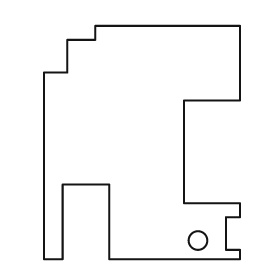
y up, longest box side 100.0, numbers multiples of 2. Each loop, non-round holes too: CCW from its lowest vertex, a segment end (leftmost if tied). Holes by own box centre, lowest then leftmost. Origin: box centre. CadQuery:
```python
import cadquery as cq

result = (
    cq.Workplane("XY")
    .moveTo(-42.0, -50.0)
    .lineTo(-34.0, -50.0)
    .lineTo(-34.0, -18.0)
    .lineTo(-14.0, -18.0)
    .lineTo(-14.0, -50.0)
    .lineTo(42.0, -50.0)
    .lineTo(42.0, -46.0)
    .lineTo(36.0, -46.0)
    .lineTo(36.0, -32.0)
    .lineTo(42.0, -32.0)
    .lineTo(42.0, -26.0)
    .lineTo(18.0, -26.0)
    .lineTo(18.0, 18.0)
    .lineTo(42.0, 18.0)
    .lineTo(42.0, 50.0)
    .lineTo(-20.0, 50.0)
    .lineTo(-20.0, 44.0)
    .lineTo(-32.0, 44.0)
    .lineTo(-32.0, 30.0)
    .lineTo(-42.0, 30.0)
    .close()
    .moveTo(24.0, -42.0)
    .circle(4.0)
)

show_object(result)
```